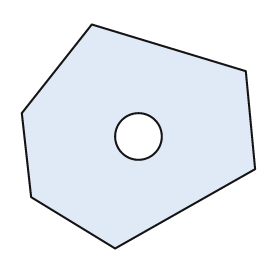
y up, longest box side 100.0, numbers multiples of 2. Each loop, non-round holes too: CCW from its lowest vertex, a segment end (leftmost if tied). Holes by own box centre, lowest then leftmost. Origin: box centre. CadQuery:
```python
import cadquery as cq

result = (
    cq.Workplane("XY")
    .moveTo(-10.0, -48.0)
    .lineTo(50.0, -14.0)
    .lineTo(46.0, 28.0)
    .lineTo(-20.0, 48.0)
    .lineTo(-50.0, 10.0)
    .lineTo(-46.0, -26.0)
    .close()
    .moveTo(0.0, 0.0)
    .circle(10.0)
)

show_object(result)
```